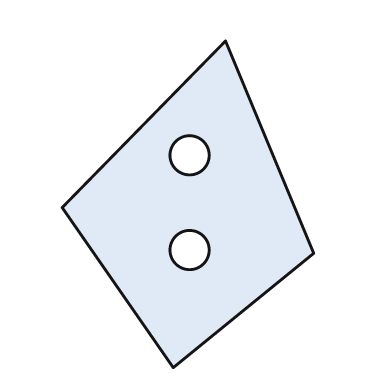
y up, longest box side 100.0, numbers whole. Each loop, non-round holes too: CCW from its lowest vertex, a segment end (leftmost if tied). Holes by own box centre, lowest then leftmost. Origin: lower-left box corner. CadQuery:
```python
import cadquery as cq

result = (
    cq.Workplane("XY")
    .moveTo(34.0, 0.0)
    .lineTo(77.0, 35.0)
    .lineTo(50.0, 100.0)
    .lineTo(0.0, 49.0)
    .close()
    .moveTo(39.0, 36.0)
    .circle(6.0)
    .moveTo(39.0, 65.0)
    .circle(6.0)
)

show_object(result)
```